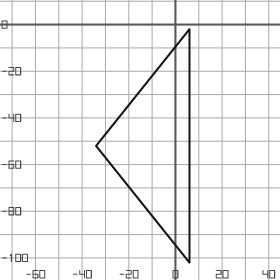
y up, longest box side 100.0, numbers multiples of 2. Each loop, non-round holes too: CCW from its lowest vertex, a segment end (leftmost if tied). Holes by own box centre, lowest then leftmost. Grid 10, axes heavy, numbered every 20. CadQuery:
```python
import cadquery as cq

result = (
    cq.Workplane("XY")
    .moveTo(6.0, -102.0)
    .lineTo(6.0, -2.0)
    .lineTo(-34.0, -52.0)
    .close()
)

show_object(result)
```